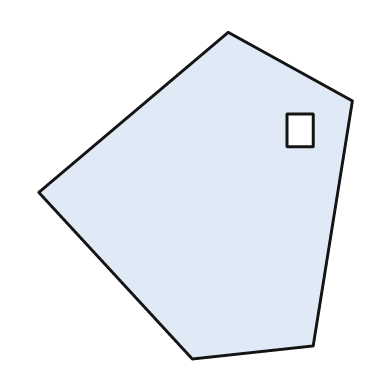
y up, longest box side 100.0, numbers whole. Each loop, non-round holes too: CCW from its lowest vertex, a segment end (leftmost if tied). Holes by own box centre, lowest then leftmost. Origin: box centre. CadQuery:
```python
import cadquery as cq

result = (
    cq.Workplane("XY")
    .moveTo(-1.0, -50.0)
    .lineTo(36.0, -46.0)
    .lineTo(48.0, 29.0)
    .lineTo(10.0, 50.0)
    .lineTo(-48.0, 1.0)
    .close()
    .moveTo(28.0, 15.0)
    .lineTo(36.0, 15.0)
    .lineTo(36.0, 25.0)
    .lineTo(28.0, 25.0)
    .close()
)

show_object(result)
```